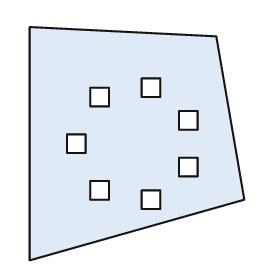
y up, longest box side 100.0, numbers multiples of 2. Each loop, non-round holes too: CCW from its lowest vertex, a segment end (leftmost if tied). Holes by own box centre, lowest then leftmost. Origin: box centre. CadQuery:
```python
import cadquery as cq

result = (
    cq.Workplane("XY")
    .moveTo(-46.0, -50.0)
    .lineTo(46.0, -24.0)
    .lineTo(34.0, 46.0)
    .lineTo(-46.0, 50.0)
    .close()
    .moveTo(2.0, -28.0)
    .lineTo(10.0, -28.0)
    .lineTo(10.0, -20.0)
    .lineTo(2.0, -20.0)
    .close()
    .moveTo(-20.0, -24.0)
    .lineTo(-12.0, -24.0)
    .lineTo(-12.0, -16.0)
    .lineTo(-20.0, -16.0)
    .close()
    .moveTo(18.0, -14.0)
    .lineTo(26.0, -14.0)
    .lineTo(26.0, -6.0)
    .lineTo(18.0, -6.0)
    .close()
    .moveTo(-30.0, -4.0)
    .lineTo(-22.0, -4.0)
    .lineTo(-22.0, 4.0)
    .lineTo(-30.0, 4.0)
    .close()
    .moveTo(18.0, 6.0)
    .lineTo(26.0, 6.0)
    .lineTo(26.0, 14.0)
    .lineTo(18.0, 14.0)
    .close()
    .moveTo(-20.0, 16.0)
    .lineTo(-12.0, 16.0)
    .lineTo(-12.0, 24.0)
    .lineTo(-20.0, 24.0)
    .close()
    .moveTo(2.0, 20.0)
    .lineTo(10.0, 20.0)
    .lineTo(10.0, 28.0)
    .lineTo(2.0, 28.0)
    .close()
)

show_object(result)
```